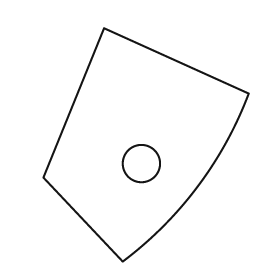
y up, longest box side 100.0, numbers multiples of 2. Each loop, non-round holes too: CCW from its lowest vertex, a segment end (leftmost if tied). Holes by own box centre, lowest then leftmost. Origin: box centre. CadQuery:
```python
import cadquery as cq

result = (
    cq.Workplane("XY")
    .moveTo(-10.0, -50.0)
    .threePointArc((22.0, -18.0), (44.0, 22.0))
    .lineTo(-18.0, 50.0)
    .lineTo(-44.0, -14.0)
    .close()
    .moveTo(-2.0, -8.0)
    .circle(8.0)
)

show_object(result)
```